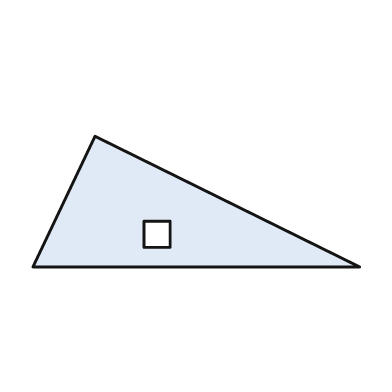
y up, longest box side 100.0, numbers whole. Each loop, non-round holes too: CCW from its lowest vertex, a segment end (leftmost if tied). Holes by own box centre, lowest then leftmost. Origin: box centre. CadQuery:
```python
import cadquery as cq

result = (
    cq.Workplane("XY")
    .moveTo(-50.0, -20.0)
    .lineTo(50.0, -20.0)
    .lineTo(-31.0, 20.0)
    .close()
    .moveTo(-16.0, -14.0)
    .lineTo(-8.0, -14.0)
    .lineTo(-8.0, -6.0)
    .lineTo(-16.0, -6.0)
    .close()
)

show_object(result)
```